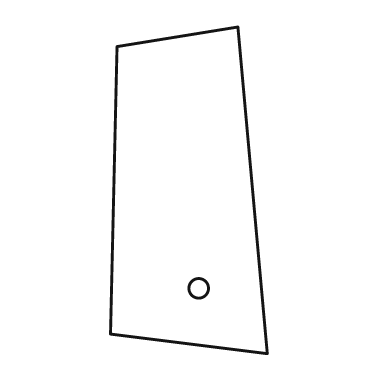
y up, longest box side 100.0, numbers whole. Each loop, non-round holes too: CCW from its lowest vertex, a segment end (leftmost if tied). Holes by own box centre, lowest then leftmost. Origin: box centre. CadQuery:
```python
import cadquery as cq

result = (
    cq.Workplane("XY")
    .moveTo(24.0, -50.0)
    .lineTo(15.0, 50.0)
    .lineTo(-22.0, 44.0)
    .lineTo(-24.0, -44.0)
    .close()
    .moveTo(3.0, -30.0)
    .circle(3.0)
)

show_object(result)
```